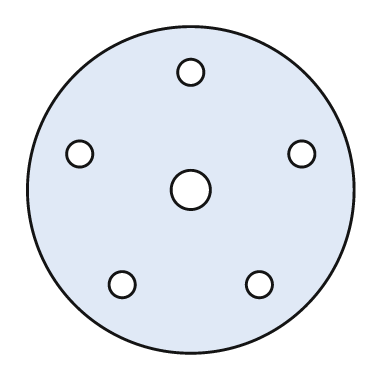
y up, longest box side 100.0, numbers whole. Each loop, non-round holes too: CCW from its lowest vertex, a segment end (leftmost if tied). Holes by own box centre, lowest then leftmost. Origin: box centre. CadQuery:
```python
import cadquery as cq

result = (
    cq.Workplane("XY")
    .moveTo(0.0, 0.0)
    .circle(50.0)
    .moveTo(-21.0, -29.0)
    .circle(4.0)
    .moveTo(21.0, -29.0)
    .circle(4.0)
    .moveTo(0.0, 0.0)
    .circle(6.0)
    .moveTo(-34.0, 11.0)
    .circle(4.0)
    .moveTo(34.0, 11.0)
    .circle(4.0)
    .moveTo(0.0, 36.0)
    .circle(4.0)
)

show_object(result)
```